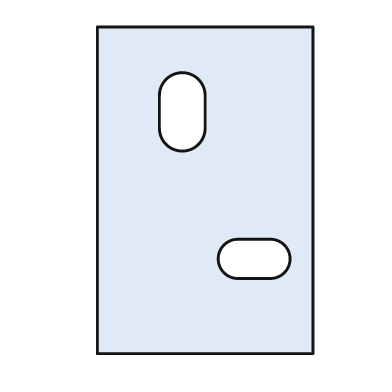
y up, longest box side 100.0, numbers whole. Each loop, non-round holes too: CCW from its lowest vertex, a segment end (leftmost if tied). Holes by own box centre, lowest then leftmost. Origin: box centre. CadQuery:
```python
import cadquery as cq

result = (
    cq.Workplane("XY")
    .moveTo(-33.0, -50.0)
    .lineTo(33.0, -50.0)
    .lineTo(33.0, 50.0)
    .lineTo(-33.0, 50.0)
    .close()
    .moveTo(10.0, -27.0)
    .lineTo(20.0, -27.0)
    .threePointArc((26.0, -21.0), (20.0, -15.0))
    .lineTo(10.0, -15.0)
    .threePointArc((4.0, -21.0), (10.0, -27.0))
    .close()
    .moveTo(-14.0, 19.0)
    .threePointArc((-7.0, 12.0), (0.0, 19.0))
    .lineTo(0.0, 29.0)
    .threePointArc((-7.0, 36.0), (-14.0, 29.0))
    .close()
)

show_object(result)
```